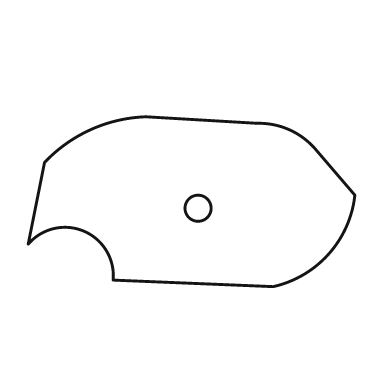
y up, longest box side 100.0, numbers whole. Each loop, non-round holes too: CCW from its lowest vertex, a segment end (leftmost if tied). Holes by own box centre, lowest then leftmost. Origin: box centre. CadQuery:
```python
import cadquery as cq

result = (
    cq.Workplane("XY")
    .moveTo(25.0, -26.0)
    .threePointArc((42.0, -16.0), (50.0, 2.0))
    .lineTo(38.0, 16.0)
    .threePointArc((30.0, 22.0), (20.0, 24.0))
    .lineTo(-14.0, 26.0)
    .threePointArc((-31.0, 22.0), (-45.0, 12.0))
    .lineTo(-50.0, -13.0)
    .threePointArc((-33.0, -9.0), (-24.0, -24.0))
    .close()
    .moveTo(2.0, -2.0)
    .circle(4.0)
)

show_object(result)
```